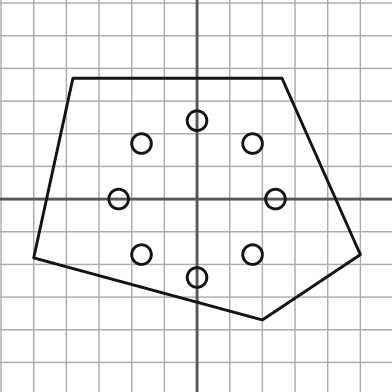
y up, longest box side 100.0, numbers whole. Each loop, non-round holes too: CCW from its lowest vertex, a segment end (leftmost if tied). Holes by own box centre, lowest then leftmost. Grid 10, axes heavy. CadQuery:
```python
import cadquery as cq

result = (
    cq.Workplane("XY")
    .moveTo(20.0, -37.0)
    .lineTo(50.0, -17.0)
    .lineTo(26.0, 37.0)
    .lineTo(-38.0, 37.0)
    .lineTo(-50.0, -18.0)
    .close()
    .moveTo(0.0, -24.0)
    .circle(3.0)
    .moveTo(-17.0, -17.0)
    .circle(3.0)
    .moveTo(17.0, -17.0)
    .circle(3.0)
    .moveTo(-24.0, 0.0)
    .circle(3.0)
    .moveTo(24.0, 0.0)
    .circle(3.0)
    .moveTo(-17.0, 17.0)
    .circle(3.0)
    .moveTo(17.0, 17.0)
    .circle(3.0)
    .moveTo(0.0, 24.0)
    .circle(3.0)
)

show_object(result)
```